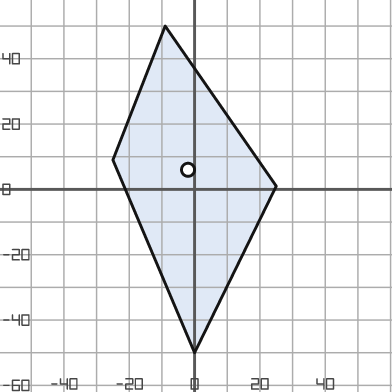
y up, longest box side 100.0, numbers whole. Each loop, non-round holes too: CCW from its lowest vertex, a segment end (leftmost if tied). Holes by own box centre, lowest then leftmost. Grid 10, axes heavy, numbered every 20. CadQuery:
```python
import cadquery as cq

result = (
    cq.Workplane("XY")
    .moveTo(0.0, -50.0)
    .lineTo(25.0, 1.0)
    .lineTo(-9.0, 50.0)
    .lineTo(-25.0, 9.0)
    .close()
    .moveTo(-2.0, 6.0)
    .circle(2.0)
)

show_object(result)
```